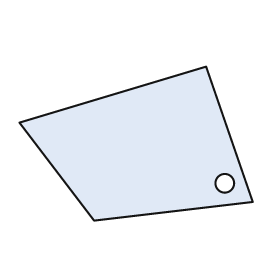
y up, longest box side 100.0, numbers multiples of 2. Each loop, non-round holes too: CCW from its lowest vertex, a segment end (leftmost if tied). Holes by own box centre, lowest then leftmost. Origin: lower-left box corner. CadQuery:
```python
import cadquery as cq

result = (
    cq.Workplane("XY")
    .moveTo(32.0, 0.0)
    .lineTo(100.0, 8.0)
    .lineTo(80.0, 66.0)
    .lineTo(0.0, 42.0)
    .close()
    .moveTo(88.0, 16.0)
    .circle(4.0)
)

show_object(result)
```